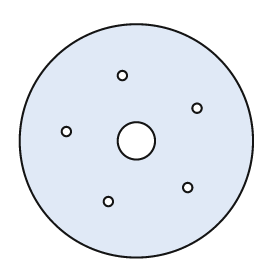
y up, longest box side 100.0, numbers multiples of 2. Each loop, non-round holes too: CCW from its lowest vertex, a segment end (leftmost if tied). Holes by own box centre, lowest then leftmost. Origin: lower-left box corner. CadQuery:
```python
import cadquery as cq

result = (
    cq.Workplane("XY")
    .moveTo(50.0, 50.0)
    .circle(50.0)
    .moveTo(38.0, 24.0)
    .circle(2.0)
    .moveTo(72.0, 30.0)
    .circle(2.0)
    .moveTo(50.0, 50.0)
    .circle(8.0)
    .moveTo(20.0, 54.0)
    .circle(2.0)
    .moveTo(76.0, 64.0)
    .circle(2.0)
    .moveTo(44.0, 78.0)
    .circle(2.0)
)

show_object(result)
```